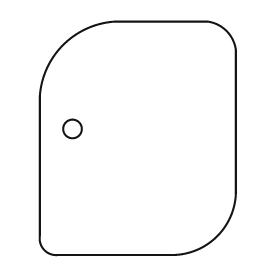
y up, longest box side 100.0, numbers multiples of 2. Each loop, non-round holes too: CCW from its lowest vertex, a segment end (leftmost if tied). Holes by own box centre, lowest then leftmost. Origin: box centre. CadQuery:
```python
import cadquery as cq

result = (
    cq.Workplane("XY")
    .moveTo(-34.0, -50.0)
    .lineTo(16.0, -50.0)
    .threePointArc((34.0, -42.0), (42.0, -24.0))
    .lineTo(42.0, 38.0)
    .threePointArc((38.0, 46.0), (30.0, 50.0))
    .lineTo(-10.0, 50.0)
    .threePointArc((-32.0, 40.0), (-42.0, 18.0))
    .lineTo(-42.0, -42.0)
    .threePointArc((-40.0, -48.0), (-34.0, -50.0))
    .close()
    .moveTo(-28.0, 4.0)
    .circle(4.0)
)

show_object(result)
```